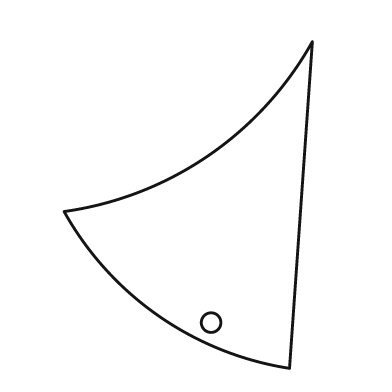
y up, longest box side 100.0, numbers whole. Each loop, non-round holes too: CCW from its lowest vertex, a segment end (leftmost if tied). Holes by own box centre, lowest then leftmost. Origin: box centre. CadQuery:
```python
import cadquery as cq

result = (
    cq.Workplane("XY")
    .moveTo(31.0, -50.0)
    .lineTo(38.0, 50.0)
    .threePointArc((6.0, 15.0), (-38.0, -2.0))
    .threePointArc((-9.0, -34.0), (31.0, -50.0))
    .close()
    .moveTo(7.0, -36.0)
    .circle(3.0)
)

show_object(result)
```